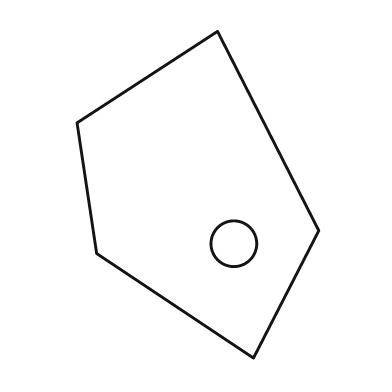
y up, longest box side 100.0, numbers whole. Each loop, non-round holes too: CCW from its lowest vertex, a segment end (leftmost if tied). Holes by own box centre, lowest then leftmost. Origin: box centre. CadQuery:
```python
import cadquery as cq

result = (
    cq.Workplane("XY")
    .moveTo(17.0, -50.0)
    .lineTo(37.0, -11.0)
    .lineTo(6.0, 50.0)
    .lineTo(-37.0, 22.0)
    .lineTo(-31.0, -18.0)
    .close()
    .moveTo(11.0, -15.0)
    .circle(7.0)
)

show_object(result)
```